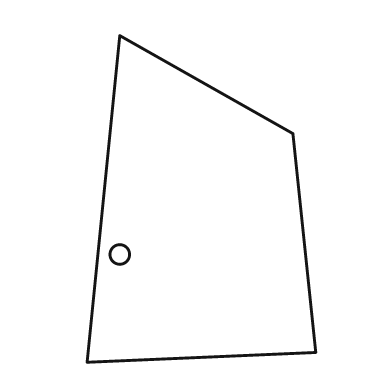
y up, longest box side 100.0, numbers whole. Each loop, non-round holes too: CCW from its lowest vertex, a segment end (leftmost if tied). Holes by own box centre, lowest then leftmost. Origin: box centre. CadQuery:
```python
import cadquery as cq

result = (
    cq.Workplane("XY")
    .moveTo(-35.0, -50.0)
    .lineTo(35.0, -47.0)
    .lineTo(28.0, 20.0)
    .lineTo(-25.0, 50.0)
    .close()
    .moveTo(-25.0, -17.0)
    .circle(3.0)
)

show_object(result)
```